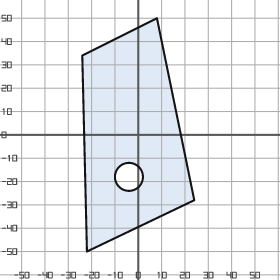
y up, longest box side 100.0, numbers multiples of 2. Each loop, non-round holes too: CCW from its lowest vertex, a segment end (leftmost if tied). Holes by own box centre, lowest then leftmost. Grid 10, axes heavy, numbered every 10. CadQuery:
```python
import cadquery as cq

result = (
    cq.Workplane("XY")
    .moveTo(-22.0, -50.0)
    .lineTo(24.0, -28.0)
    .lineTo(8.0, 50.0)
    .lineTo(-24.0, 34.0)
    .close()
    .moveTo(-4.0, -18.0)
    .circle(6.0)
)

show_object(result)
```